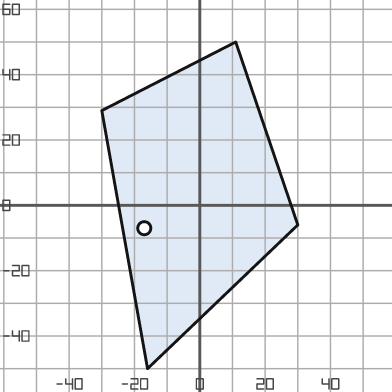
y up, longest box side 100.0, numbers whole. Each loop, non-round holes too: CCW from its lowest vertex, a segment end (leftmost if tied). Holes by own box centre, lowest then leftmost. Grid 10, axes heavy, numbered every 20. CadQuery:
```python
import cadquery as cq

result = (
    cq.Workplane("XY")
    .moveTo(-16.0, -50.0)
    .lineTo(30.0, -6.0)
    .lineTo(11.0, 50.0)
    .lineTo(-30.0, 29.0)
    .close()
    .moveTo(-17.0, -7.0)
    .circle(2.0)
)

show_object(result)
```